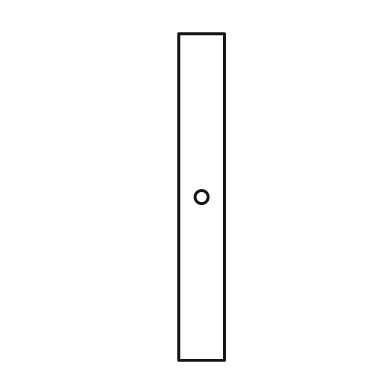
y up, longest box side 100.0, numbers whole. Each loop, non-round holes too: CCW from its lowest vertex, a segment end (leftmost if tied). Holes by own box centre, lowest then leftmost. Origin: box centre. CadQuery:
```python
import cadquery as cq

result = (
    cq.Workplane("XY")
    .moveTo(-7.0, -50.0)
    .lineTo(7.0, -50.0)
    .lineTo(7.0, 50.0)
    .lineTo(-7.0, 50.0)
    .close()
    .moveTo(0.0, 0.0)
    .circle(2.0)
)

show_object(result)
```